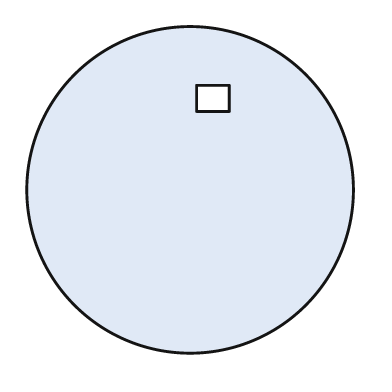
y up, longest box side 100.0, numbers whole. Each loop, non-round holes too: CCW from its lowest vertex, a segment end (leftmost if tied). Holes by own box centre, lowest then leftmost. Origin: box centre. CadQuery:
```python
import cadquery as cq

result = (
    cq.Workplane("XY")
    .moveTo(0.0, 0.0)
    .circle(50.0)
    .moveTo(2.0, 24.0)
    .lineTo(12.0, 24.0)
    .lineTo(12.0, 32.0)
    .lineTo(2.0, 32.0)
    .close()
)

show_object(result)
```